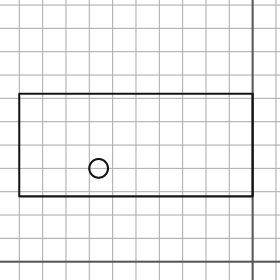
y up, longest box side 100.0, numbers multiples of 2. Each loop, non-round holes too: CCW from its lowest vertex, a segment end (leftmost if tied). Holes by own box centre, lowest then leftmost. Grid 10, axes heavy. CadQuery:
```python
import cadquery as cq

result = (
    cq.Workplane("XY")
    .moveTo(-100.0, 28.0)
    .lineTo(0.0, 28.0)
    .lineTo(0.0, 72.0)
    .lineTo(-100.0, 72.0)
    .close()
    .moveTo(-66.0, 40.0)
    .circle(4.0)
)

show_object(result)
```